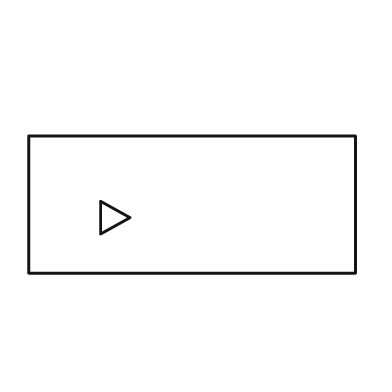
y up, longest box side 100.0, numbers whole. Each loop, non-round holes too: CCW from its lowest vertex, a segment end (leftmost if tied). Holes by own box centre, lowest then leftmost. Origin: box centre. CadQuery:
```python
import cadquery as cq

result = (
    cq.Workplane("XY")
    .moveTo(-50.0, -21.0)
    .lineTo(50.0, -21.0)
    .lineTo(50.0, 21.0)
    .lineTo(-50.0, 21.0)
    .close()
    .moveTo(-28.0, -9.0)
    .lineTo(-19.0, -4.0)
    .lineTo(-28.0, 1.0)
    .close()
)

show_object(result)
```